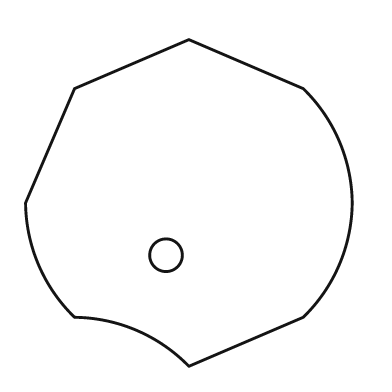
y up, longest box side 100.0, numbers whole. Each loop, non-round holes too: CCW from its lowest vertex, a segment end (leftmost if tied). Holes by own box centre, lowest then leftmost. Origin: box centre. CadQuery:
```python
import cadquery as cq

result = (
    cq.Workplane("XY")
    .moveTo(0.0, -50.0)
    .lineTo(35.0, -35.0)
    .threePointArc((46.0, -19.0), (50.0, 0.0))
    .threePointArc((46.0, 19.0), (35.0, 35.0))
    .lineTo(0.0, 50.0)
    .lineTo(-35.0, 35.0)
    .lineTo(-50.0, 0.0)
    .threePointArc((-46.0, -19.0), (-35.0, -35.0))
    .threePointArc((-16.0, -39.0), (0.0, -50.0))
    .close()
    .moveTo(-7.0, -16.0)
    .circle(5.0)
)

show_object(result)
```